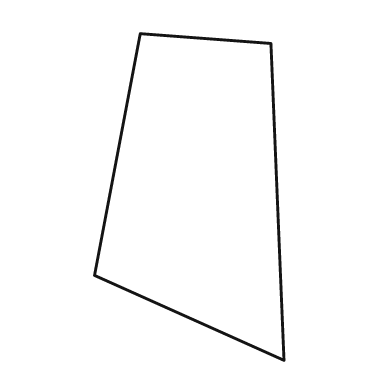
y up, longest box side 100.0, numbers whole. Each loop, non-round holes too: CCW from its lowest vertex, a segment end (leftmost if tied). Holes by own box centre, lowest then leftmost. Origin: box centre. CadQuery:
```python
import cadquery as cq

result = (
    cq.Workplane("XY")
    .moveTo(29.0, -50.0)
    .lineTo(25.0, 47.0)
    .lineTo(-15.0, 50.0)
    .lineTo(-29.0, -24.0)
    .close()
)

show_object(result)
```